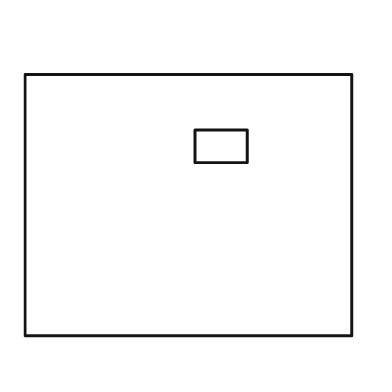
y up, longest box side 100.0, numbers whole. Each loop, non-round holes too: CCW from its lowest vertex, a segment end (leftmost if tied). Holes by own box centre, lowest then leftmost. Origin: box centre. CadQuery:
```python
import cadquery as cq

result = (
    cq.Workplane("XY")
    .moveTo(-50.0, -40.0)
    .lineTo(50.0, -40.0)
    .lineTo(50.0, 40.0)
    .lineTo(-50.0, 40.0)
    .close()
    .moveTo(2.0, 13.0)
    .lineTo(18.0, 13.0)
    .lineTo(18.0, 23.0)
    .lineTo(2.0, 23.0)
    .close()
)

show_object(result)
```